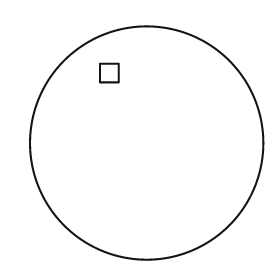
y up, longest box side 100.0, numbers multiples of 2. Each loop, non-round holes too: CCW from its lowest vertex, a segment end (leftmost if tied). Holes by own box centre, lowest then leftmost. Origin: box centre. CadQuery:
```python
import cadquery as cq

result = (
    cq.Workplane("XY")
    .moveTo(0.0, 0.0)
    .circle(50.0)
    .moveTo(-20.0, 26.0)
    .lineTo(-12.0, 26.0)
    .lineTo(-12.0, 34.0)
    .lineTo(-20.0, 34.0)
    .close()
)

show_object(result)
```